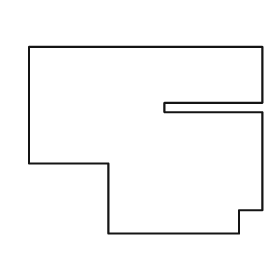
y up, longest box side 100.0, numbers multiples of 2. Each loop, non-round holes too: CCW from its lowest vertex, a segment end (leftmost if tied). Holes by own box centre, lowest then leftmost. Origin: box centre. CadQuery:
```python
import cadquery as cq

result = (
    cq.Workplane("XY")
    .moveTo(-16.0, -40.0)
    .lineTo(40.0, -40.0)
    .lineTo(40.0, -30.0)
    .lineTo(50.0, -30.0)
    .lineTo(50.0, 12.0)
    .lineTo(8.0, 12.0)
    .lineTo(8.0, 16.0)
    .lineTo(50.0, 16.0)
    .lineTo(50.0, 40.0)
    .lineTo(-50.0, 40.0)
    .lineTo(-50.0, -10.0)
    .lineTo(-16.0, -10.0)
    .close()
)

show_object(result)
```